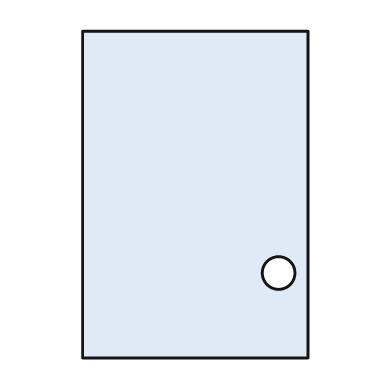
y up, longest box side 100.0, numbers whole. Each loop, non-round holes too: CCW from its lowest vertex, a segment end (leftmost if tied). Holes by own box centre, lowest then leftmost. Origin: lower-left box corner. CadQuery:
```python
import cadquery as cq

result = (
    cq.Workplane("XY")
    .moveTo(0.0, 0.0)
    .lineTo(69.0, 0.0)
    .lineTo(69.0, 100.0)
    .lineTo(0.0, 100.0)
    .close()
    .moveTo(60.0, 26.0)
    .circle(5.0)
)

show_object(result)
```